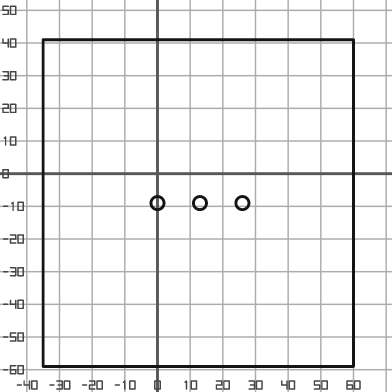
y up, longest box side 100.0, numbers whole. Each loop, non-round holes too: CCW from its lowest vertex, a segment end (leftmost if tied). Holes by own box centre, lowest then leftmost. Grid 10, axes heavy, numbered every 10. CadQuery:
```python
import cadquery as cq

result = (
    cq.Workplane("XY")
    .moveTo(-35.0, -59.0)
    .lineTo(60.0, -59.0)
    .lineTo(60.0, 41.0)
    .lineTo(-35.0, 41.0)
    .close()
    .moveTo(0.0, -9.0)
    .circle(2.0)
    .moveTo(13.0, -9.0)
    .circle(2.0)
    .moveTo(26.0, -9.0)
    .circle(2.0)
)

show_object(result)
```